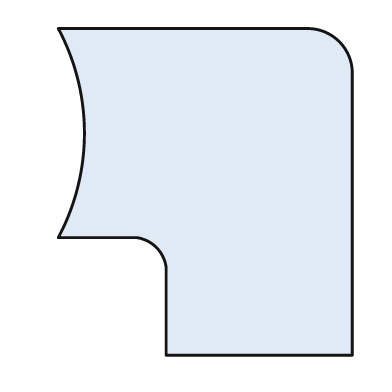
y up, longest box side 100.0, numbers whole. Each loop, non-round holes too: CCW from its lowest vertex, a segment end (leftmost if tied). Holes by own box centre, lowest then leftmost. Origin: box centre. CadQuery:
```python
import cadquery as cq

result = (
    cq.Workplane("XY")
    .moveTo(-12.0, -50.0)
    .lineTo(45.0, -50.0)
    .lineTo(45.0, 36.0)
    .threePointArc((41.0, 46.0), (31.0, 50.0))
    .lineTo(-45.0, 50.0)
    .threePointArc((-37.0, 18.0), (-45.0, -14.0))
    .lineTo(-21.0, -14.0)
    .threePointArc((-15.0, -17.0), (-12.0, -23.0))
    .close()
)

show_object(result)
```